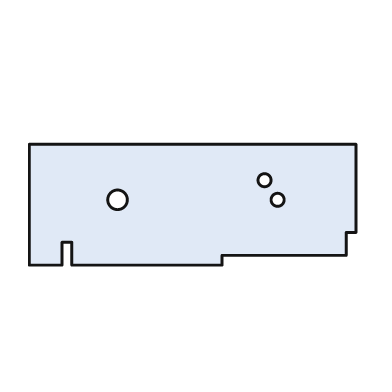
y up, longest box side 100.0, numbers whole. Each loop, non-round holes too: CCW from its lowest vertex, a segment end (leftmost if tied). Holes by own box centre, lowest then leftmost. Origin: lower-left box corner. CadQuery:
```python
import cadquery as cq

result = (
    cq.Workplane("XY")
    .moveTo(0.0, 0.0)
    .lineTo(10.0, 0.0)
    .lineTo(10.0, 7.0)
    .lineTo(13.0, 7.0)
    .lineTo(13.0, 0.0)
    .lineTo(59.0, 0.0)
    .lineTo(59.0, 3.0)
    .lineTo(97.0, 3.0)
    .lineTo(97.0, 10.0)
    .lineTo(100.0, 10.0)
    .lineTo(100.0, 37.0)
    .lineTo(0.0, 37.0)
    .close()
    .moveTo(27.0, 20.0)
    .circle(3.0)
    .moveTo(76.0, 20.0)
    .circle(2.0)
    .moveTo(72.0, 26.0)
    .circle(2.0)
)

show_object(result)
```